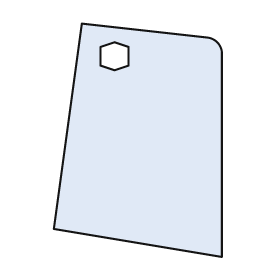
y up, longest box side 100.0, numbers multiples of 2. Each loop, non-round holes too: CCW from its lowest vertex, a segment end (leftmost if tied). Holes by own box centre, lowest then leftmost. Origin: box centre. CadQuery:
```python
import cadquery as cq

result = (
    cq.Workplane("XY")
    .moveTo(36.0, -50.0)
    .lineTo(36.0, 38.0)
    .threePointArc((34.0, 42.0), (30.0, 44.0))
    .lineTo(-24.0, 50.0)
    .lineTo(-36.0, -38.0)
    .close()
    .moveTo(-10.0, 30.0)
    .lineTo(-4.0, 32.0)
    .lineTo(-4.0, 40.0)
    .lineTo(-10.0, 42.0)
    .lineTo(-16.0, 40.0)
    .lineTo(-16.0, 32.0)
    .close()
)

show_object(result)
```